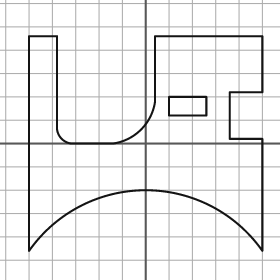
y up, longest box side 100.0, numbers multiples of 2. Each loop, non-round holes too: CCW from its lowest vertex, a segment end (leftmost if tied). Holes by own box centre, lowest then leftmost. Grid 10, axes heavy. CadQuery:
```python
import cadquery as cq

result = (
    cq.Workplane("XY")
    .moveTo(-50.0, -46.0)
    .threePointArc((0.0, -20.0), (50.0, -46.0))
    .lineTo(50.0, 2.0)
    .lineTo(36.0, 2.0)
    .lineTo(36.0, 22.0)
    .lineTo(50.0, 22.0)
    .lineTo(50.0, 46.0)
    .lineTo(4.0, 46.0)
    .lineTo(4.0, 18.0)
    .threePointArc((-2.0, 6.0), (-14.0, 0.0))
    .lineTo(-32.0, 0.0)
    .threePointArc((-36.0, 2.0), (-38.0, 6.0))
    .lineTo(-38.0, 46.0)
    .lineTo(-50.0, 46.0)
    .close()
    .moveTo(10.0, 12.0)
    .lineTo(26.0, 12.0)
    .lineTo(26.0, 20.0)
    .lineTo(10.0, 20.0)
    .close()
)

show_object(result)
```